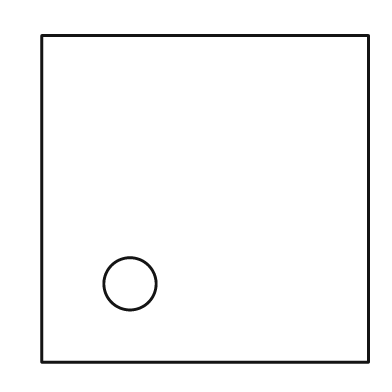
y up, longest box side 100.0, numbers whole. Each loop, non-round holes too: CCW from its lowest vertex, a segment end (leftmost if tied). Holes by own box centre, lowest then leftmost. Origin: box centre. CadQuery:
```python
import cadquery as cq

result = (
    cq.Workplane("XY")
    .moveTo(-50.0, -50.0)
    .lineTo(50.0, -50.0)
    .lineTo(50.0, 50.0)
    .lineTo(-50.0, 50.0)
    .close()
    .moveTo(-23.0, -26.0)
    .circle(8.0)
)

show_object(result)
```